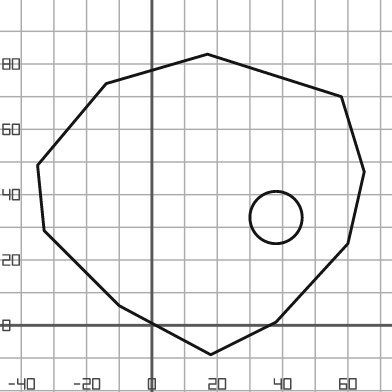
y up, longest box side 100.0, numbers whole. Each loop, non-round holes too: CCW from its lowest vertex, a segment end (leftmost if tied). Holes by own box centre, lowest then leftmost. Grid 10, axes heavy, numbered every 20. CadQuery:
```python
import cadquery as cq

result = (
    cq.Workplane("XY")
    .moveTo(18.0, -9.0)
    .lineTo(38.0, 1.0)
    .lineTo(60.0, 25.0)
    .lineTo(65.0, 47.0)
    .lineTo(58.0, 70.0)
    .lineTo(17.0, 83.0)
    .lineTo(-14.0, 74.0)
    .lineTo(-35.0, 49.0)
    .lineTo(-33.0, 29.0)
    .lineTo(-10.0, 6.0)
    .close()
    .moveTo(38.0, 33.0)
    .circle(8.0)
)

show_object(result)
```